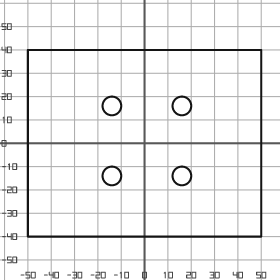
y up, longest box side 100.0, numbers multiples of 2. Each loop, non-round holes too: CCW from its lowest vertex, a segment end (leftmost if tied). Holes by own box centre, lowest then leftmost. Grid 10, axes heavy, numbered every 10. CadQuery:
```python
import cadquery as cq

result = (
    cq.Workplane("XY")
    .moveTo(-50.0, -40.0)
    .lineTo(50.0, -40.0)
    .lineTo(50.0, 40.0)
    .lineTo(-50.0, 40.0)
    .close()
    .moveTo(-14.0, -14.0)
    .circle(4.0)
    .moveTo(16.0, -14.0)
    .circle(4.0)
    .moveTo(-14.0, 16.0)
    .circle(4.0)
    .moveTo(16.0, 16.0)
    .circle(4.0)
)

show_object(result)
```